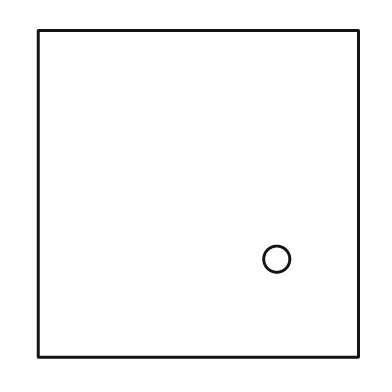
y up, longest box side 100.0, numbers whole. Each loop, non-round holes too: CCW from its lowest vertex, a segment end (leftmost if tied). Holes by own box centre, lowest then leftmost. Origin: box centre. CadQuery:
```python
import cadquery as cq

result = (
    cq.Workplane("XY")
    .moveTo(-49.0, -50.0)
    .lineTo(49.0, -50.0)
    .lineTo(49.0, 50.0)
    .lineTo(-49.0, 50.0)
    .close()
    .moveTo(24.0, -20.0)
    .circle(4.0)
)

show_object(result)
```